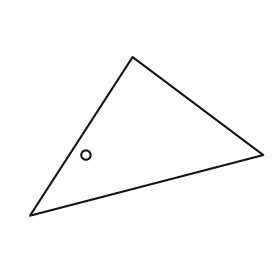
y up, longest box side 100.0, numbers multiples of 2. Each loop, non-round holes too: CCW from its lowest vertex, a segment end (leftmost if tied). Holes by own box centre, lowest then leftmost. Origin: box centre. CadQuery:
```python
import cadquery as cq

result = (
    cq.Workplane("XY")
    .moveTo(-50.0, -34.0)
    .lineTo(50.0, -8.0)
    .lineTo(-6.0, 34.0)
    .close()
    .moveTo(-26.0, -8.0)
    .circle(2.0)
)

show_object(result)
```